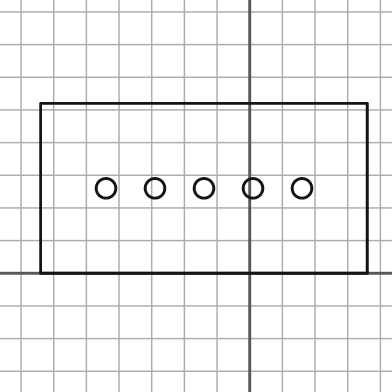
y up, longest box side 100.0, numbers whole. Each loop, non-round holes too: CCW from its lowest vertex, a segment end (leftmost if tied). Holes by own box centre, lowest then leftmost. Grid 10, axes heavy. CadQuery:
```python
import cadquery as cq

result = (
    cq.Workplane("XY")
    .moveTo(-64.0, 0.0)
    .lineTo(36.0, 0.0)
    .lineTo(36.0, 52.0)
    .lineTo(-64.0, 52.0)
    .close()
    .moveTo(-44.0, 26.0)
    .circle(3.0)
    .moveTo(-29.0, 26.0)
    .circle(3.0)
    .moveTo(-14.0, 26.0)
    .circle(3.0)
    .moveTo(1.0, 26.0)
    .circle(3.0)
    .moveTo(16.0, 26.0)
    .circle(3.0)
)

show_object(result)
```